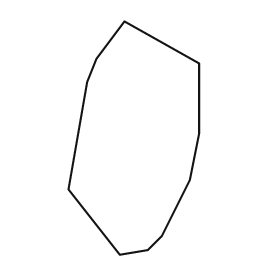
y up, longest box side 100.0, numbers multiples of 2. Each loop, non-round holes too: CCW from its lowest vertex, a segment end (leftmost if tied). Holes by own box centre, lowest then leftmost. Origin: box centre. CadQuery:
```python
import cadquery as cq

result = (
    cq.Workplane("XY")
    .moveTo(-6.0, -50.0)
    .lineTo(6.0, -48.0)
    .lineTo(12.0, -42.0)
    .lineTo(24.0, -18.0)
    .lineTo(28.0, 2.0)
    .lineTo(28.0, 32.0)
    .lineTo(-4.0, 50.0)
    .lineTo(-16.0, 34.0)
    .lineTo(-20.0, 24.0)
    .lineTo(-28.0, -22.0)
    .close()
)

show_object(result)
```